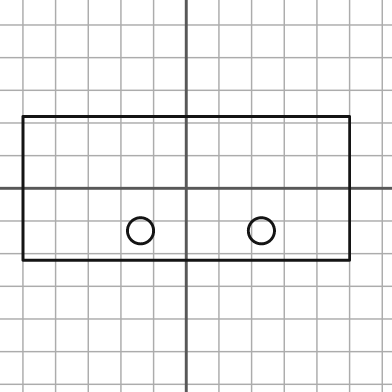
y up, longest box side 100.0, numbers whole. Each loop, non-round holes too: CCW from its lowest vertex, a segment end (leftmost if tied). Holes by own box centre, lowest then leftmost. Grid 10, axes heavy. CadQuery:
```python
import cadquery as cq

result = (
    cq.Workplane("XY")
    .moveTo(-50.0, -22.0)
    .lineTo(50.0, -22.0)
    .lineTo(50.0, 22.0)
    .lineTo(-50.0, 22.0)
    .close()
    .moveTo(-14.0, -13.0)
    .circle(4.0)
    .moveTo(23.0, -13.0)
    .circle(4.0)
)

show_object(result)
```